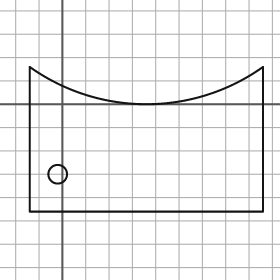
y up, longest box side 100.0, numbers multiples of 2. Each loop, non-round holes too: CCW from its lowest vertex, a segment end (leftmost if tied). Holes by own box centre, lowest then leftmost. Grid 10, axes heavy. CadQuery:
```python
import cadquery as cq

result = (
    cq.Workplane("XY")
    .moveTo(-14.0, -46.0)
    .lineTo(86.0, -46.0)
    .lineTo(86.0, 16.0)
    .threePointArc((36.0, 0.0), (-14.0, 16.0))
    .close()
    .moveTo(-2.0, -30.0)
    .circle(4.0)
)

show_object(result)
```